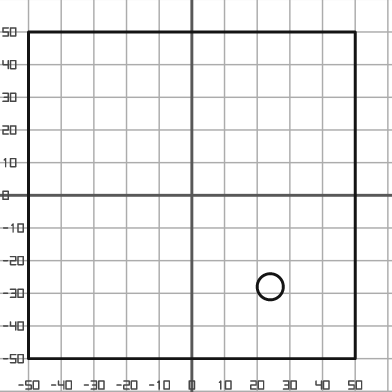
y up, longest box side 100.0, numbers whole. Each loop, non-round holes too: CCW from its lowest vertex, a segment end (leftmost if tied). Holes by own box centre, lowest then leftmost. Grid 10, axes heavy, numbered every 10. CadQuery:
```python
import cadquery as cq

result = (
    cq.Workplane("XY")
    .moveTo(-50.0, -50.0)
    .lineTo(50.0, -50.0)
    .lineTo(50.0, 50.0)
    .lineTo(-50.0, 50.0)
    .close()
    .moveTo(24.0, -28.0)
    .circle(4.0)
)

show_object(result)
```